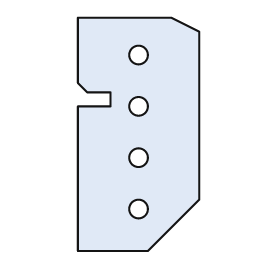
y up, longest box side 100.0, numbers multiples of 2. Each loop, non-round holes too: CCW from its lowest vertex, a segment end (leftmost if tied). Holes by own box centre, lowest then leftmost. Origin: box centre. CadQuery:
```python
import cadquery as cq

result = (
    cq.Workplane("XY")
    .moveTo(-26.0, -50.0)
    .lineTo(4.0, -50.0)
    .lineTo(26.0, -28.0)
    .lineTo(26.0, 44.0)
    .lineTo(14.0, 50.0)
    .lineTo(-26.0, 50.0)
    .lineTo(-26.0, 22.0)
    .lineTo(-22.0, 18.0)
    .lineTo(-12.0, 18.0)
    .lineTo(-12.0, 12.0)
    .lineTo(-26.0, 12.0)
    .close()
    .moveTo(0.0, -32.0)
    .circle(4.0)
    .moveTo(0.0, -10.0)
    .circle(4.0)
    .moveTo(0.0, 12.0)
    .circle(4.0)
    .moveTo(0.0, 34.0)
    .circle(4.0)
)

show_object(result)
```